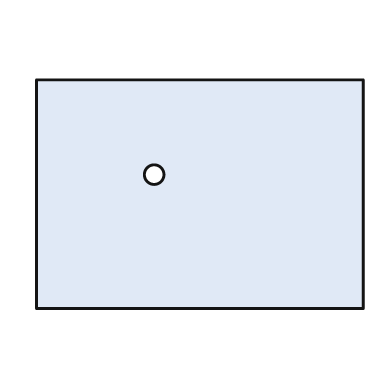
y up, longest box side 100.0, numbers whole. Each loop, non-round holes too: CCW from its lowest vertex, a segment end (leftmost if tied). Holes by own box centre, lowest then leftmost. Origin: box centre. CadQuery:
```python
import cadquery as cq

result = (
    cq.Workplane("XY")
    .moveTo(-50.0, -35.0)
    .lineTo(50.0, -35.0)
    .lineTo(50.0, 35.0)
    .lineTo(-50.0, 35.0)
    .close()
    .moveTo(-14.0, 6.0)
    .circle(3.0)
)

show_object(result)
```